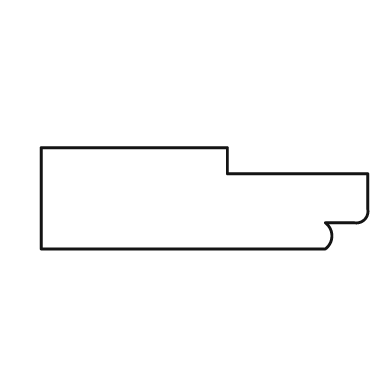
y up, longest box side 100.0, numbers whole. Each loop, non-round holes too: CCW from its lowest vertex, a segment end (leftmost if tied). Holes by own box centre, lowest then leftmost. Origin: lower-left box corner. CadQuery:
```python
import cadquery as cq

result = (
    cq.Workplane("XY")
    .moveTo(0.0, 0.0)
    .lineTo(87.0, 0.0)
    .threePointArc((89.0, 4.0), (87.0, 8.0))
    .lineTo(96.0, 8.0)
    .threePointArc((99.0, 9.0), (100.0, 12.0))
    .lineTo(100.0, 23.0)
    .lineTo(57.0, 23.0)
    .lineTo(57.0, 31.0)
    .lineTo(0.0, 31.0)
    .close()
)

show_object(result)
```